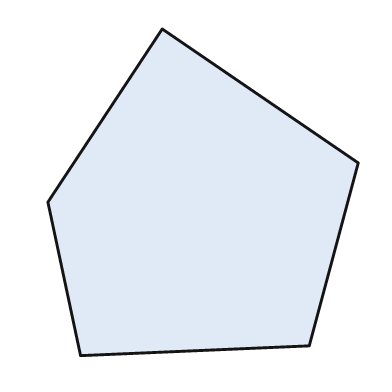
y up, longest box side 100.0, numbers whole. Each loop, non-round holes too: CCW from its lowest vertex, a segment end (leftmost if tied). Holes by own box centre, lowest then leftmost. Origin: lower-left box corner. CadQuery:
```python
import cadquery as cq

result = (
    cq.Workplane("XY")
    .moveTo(10.0, 0.0)
    .lineTo(80.0, 3.0)
    .lineTo(95.0, 59.0)
    .lineTo(35.0, 100.0)
    .lineTo(0.0, 47.0)
    .close()
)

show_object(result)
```